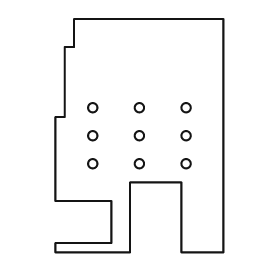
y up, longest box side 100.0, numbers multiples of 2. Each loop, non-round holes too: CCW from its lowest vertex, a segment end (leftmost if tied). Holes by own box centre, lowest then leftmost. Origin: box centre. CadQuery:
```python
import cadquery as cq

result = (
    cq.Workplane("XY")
    .moveTo(-36.0, -50.0)
    .lineTo(-4.0, -50.0)
    .lineTo(-4.0, -20.0)
    .lineTo(18.0, -20.0)
    .lineTo(18.0, -50.0)
    .lineTo(36.0, -50.0)
    .lineTo(36.0, 50.0)
    .lineTo(-28.0, 50.0)
    .lineTo(-28.0, 38.0)
    .lineTo(-32.0, 38.0)
    .lineTo(-32.0, 8.0)
    .lineTo(-36.0, 8.0)
    .lineTo(-36.0, -28.0)
    .lineTo(-12.0, -28.0)
    .lineTo(-12.0, -46.0)
    .lineTo(-36.0, -46.0)
    .close()
    .moveTo(-20.0, -12.0)
    .circle(2.0)
    .moveTo(0.0, -12.0)
    .circle(2.0)
    .moveTo(20.0, -12.0)
    .circle(2.0)
    .moveTo(-20.0, 0.0)
    .circle(2.0)
    .moveTo(0.0, 0.0)
    .circle(2.0)
    .moveTo(20.0, 0.0)
    .circle(2.0)
    .moveTo(-20.0, 12.0)
    .circle(2.0)
    .moveTo(0.0, 12.0)
    .circle(2.0)
    .moveTo(20.0, 12.0)
    .circle(2.0)
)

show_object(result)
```